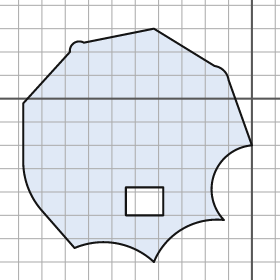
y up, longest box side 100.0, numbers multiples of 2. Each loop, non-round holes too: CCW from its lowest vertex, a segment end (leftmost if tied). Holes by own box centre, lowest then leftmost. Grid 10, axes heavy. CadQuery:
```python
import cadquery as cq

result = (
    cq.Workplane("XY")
    .moveTo(-42.0, -70.0)
    .threePointArc((-30.0, -56.0), (-12.0, -52.0))
    .threePointArc((-16.0, -32.0), (0.0, -20.0))
    .lineTo(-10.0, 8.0)
    .threePointArc((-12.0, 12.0), (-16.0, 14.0))
    .lineTo(-42.0, 30.0)
    .lineTo(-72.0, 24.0)
    .threePointArc((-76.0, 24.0), (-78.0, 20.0))
    .lineTo(-98.0, -2.0)
    .lineTo(-98.0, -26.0)
    .threePointArc((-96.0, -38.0), (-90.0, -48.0))
    .lineTo(-76.0, -64.0)
    .threePointArc((-58.0, -62.0), (-42.0, -70.0))
    .close()
    .moveTo(-54.0, -50.0)
    .lineTo(-38.0, -50.0)
    .lineTo(-38.0, -38.0)
    .lineTo(-54.0, -38.0)
    .close()
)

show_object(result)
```